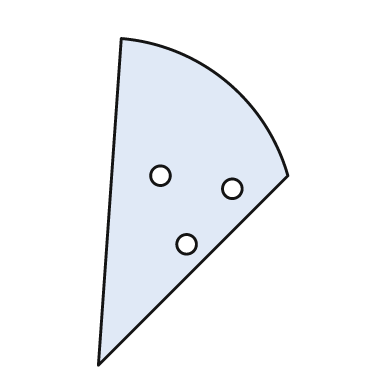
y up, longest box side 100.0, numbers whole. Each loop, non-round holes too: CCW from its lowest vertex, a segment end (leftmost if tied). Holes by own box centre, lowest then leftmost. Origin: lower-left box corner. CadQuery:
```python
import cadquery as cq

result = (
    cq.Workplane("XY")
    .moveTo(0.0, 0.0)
    .lineTo(58.0, 58.0)
    .threePointArc((39.0, 87.0), (7.0, 100.0))
    .close()
    .moveTo(27.0, 37.0)
    .circle(3.0)
    .moveTo(41.0, 54.0)
    .circle(3.0)
    .moveTo(19.0, 58.0)
    .circle(3.0)
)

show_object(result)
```